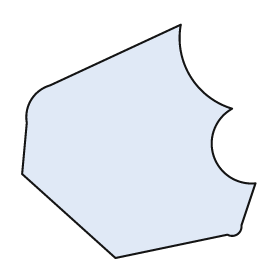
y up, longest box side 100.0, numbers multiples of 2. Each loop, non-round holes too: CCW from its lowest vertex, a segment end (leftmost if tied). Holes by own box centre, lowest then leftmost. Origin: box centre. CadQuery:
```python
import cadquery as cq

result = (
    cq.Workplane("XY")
    .moveTo(-10.0, -50.0)
    .lineTo(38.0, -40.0)
    .threePointArc((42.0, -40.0), (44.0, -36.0))
    .lineTo(50.0, -18.0)
    .threePointArc((32.0, -6.0), (40.0, 14.0))
    .threePointArc((22.0, 28.0), (18.0, 50.0))
    .lineTo(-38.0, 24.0)
    .threePointArc((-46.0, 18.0), (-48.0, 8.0))
    .lineTo(-50.0, -14.0)
    .close()
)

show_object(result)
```